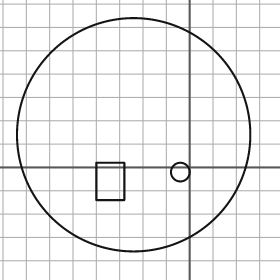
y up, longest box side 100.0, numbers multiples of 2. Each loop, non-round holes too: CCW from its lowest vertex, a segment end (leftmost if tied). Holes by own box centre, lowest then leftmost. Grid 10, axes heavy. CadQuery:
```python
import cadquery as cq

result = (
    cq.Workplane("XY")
    .moveTo(-24.0, 14.0)
    .circle(50.0)
    .moveTo(-40.0, -14.0)
    .lineTo(-28.0, -14.0)
    .lineTo(-28.0, 2.0)
    .lineTo(-40.0, 2.0)
    .close()
    .moveTo(-4.0, -2.0)
    .circle(4.0)
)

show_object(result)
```